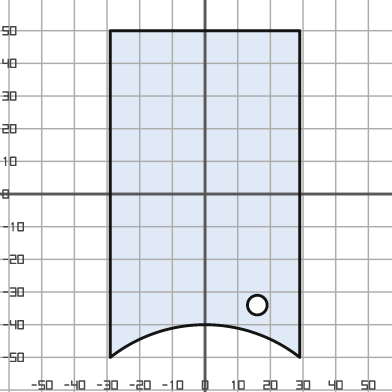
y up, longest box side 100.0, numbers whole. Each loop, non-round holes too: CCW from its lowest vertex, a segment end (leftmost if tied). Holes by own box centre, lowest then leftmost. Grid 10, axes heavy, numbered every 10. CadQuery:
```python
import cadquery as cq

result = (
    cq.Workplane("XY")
    .moveTo(-29.0, -50.0)
    .threePointArc((0.0, -40.0), (29.0, -50.0))
    .lineTo(29.0, 50.0)
    .lineTo(-29.0, 50.0)
    .close()
    .moveTo(16.0, -34.0)
    .circle(3.0)
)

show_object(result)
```